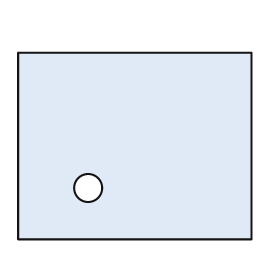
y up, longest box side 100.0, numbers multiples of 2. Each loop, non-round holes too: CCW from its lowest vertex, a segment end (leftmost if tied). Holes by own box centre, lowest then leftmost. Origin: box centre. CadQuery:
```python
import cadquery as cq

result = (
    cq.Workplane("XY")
    .moveTo(-50.0, -40.0)
    .lineTo(50.0, -40.0)
    .lineTo(50.0, 40.0)
    .lineTo(-50.0, 40.0)
    .close()
    .moveTo(-20.0, -18.0)
    .circle(6.0)
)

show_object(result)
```